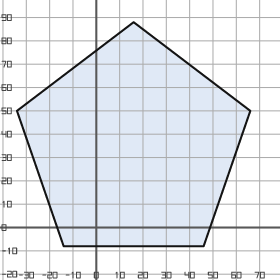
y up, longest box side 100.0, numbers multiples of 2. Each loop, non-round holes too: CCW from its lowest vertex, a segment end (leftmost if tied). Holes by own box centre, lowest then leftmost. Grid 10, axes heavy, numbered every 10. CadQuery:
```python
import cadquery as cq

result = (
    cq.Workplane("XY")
    .moveTo(-14.0, -8.0)
    .lineTo(46.0, -8.0)
    .lineTo(66.0, 50.0)
    .lineTo(16.0, 88.0)
    .lineTo(-34.0, 50.0)
    .close()
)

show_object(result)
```